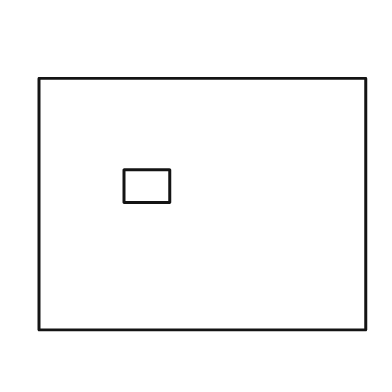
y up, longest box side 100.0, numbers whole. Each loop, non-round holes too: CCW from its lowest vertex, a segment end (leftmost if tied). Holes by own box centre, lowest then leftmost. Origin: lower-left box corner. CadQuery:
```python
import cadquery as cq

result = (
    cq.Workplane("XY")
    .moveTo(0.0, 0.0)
    .lineTo(100.0, 0.0)
    .lineTo(100.0, 77.0)
    .lineTo(0.0, 77.0)
    .close()
    .moveTo(26.0, 39.0)
    .lineTo(40.0, 39.0)
    .lineTo(40.0, 49.0)
    .lineTo(26.0, 49.0)
    .close()
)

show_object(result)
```